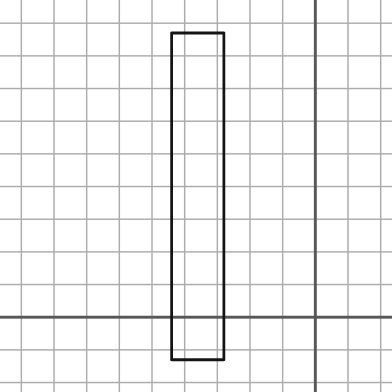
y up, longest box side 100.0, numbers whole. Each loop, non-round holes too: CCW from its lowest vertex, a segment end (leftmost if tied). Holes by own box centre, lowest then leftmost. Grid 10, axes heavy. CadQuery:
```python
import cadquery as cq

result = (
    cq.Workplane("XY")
    .moveTo(-44.0, -13.0)
    .lineTo(-28.0, -13.0)
    .lineTo(-28.0, 87.0)
    .lineTo(-44.0, 87.0)
    .close()
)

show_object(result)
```